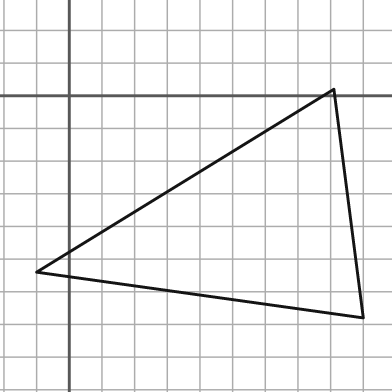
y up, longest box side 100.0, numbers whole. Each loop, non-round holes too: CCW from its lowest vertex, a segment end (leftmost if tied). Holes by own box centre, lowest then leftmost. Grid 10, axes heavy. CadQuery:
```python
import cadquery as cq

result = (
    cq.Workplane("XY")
    .moveTo(90.0, -68.0)
    .lineTo(81.0, 2.0)
    .lineTo(-10.0, -54.0)
    .close()
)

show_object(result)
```